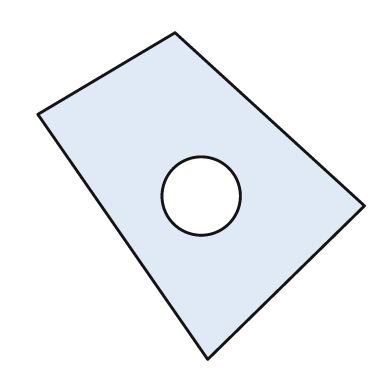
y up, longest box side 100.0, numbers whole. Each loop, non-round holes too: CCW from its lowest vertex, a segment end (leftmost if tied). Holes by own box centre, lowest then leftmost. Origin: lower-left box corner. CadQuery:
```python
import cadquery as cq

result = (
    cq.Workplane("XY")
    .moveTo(52.0, 0.0)
    .lineTo(100.0, 47.0)
    .lineTo(42.0, 100.0)
    .lineTo(0.0, 75.0)
    .close()
    .moveTo(50.0, 50.0)
    .circle(12.0)
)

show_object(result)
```